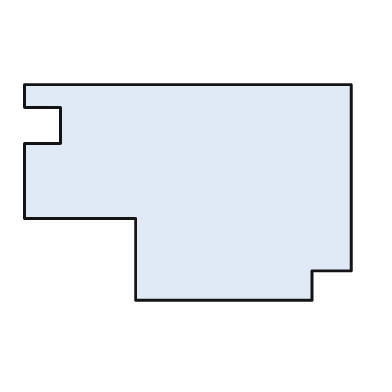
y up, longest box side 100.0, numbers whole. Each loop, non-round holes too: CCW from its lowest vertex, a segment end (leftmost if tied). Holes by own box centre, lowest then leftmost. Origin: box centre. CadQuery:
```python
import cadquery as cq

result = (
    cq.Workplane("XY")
    .moveTo(-16.0, -33.0)
    .lineTo(38.0, -33.0)
    .lineTo(38.0, -24.0)
    .lineTo(50.0, -24.0)
    .lineTo(50.0, 33.0)
    .lineTo(-50.0, 33.0)
    .lineTo(-50.0, 26.0)
    .lineTo(-39.0, 26.0)
    .lineTo(-39.0, 15.0)
    .lineTo(-50.0, 15.0)
    .lineTo(-50.0, -8.0)
    .lineTo(-16.0, -8.0)
    .close()
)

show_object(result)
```